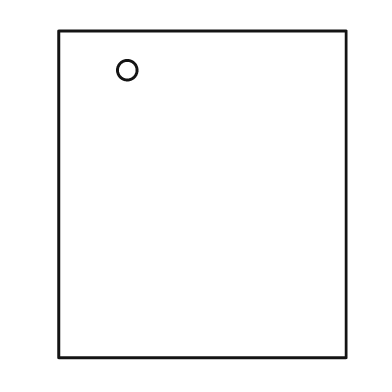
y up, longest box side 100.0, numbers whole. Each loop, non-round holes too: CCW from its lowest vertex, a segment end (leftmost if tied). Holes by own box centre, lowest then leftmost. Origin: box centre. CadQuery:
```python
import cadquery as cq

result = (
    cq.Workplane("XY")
    .moveTo(-44.0, -50.0)
    .lineTo(44.0, -50.0)
    .lineTo(44.0, 50.0)
    .lineTo(-44.0, 50.0)
    .close()
    .moveTo(-23.0, 38.0)
    .circle(3.0)
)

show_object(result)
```